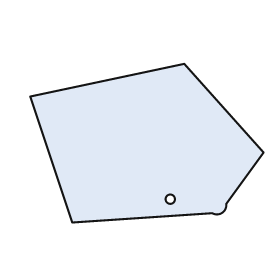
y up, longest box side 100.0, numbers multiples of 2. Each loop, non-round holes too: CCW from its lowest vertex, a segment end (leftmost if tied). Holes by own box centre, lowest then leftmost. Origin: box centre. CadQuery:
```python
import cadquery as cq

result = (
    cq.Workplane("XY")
    .moveTo(-32.0, -34.0)
    .lineTo(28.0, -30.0)
    .threePointArc((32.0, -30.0), (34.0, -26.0))
    .lineTo(50.0, -4.0)
    .lineTo(16.0, 34.0)
    .lineTo(-50.0, 20.0)
    .close()
    .moveTo(10.0, -24.0)
    .circle(2.0)
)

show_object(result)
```